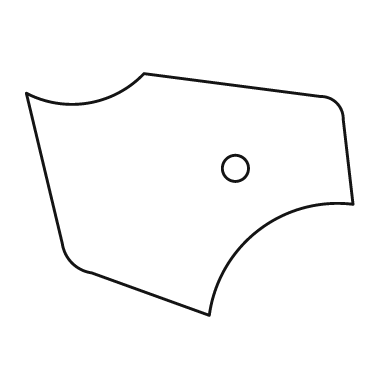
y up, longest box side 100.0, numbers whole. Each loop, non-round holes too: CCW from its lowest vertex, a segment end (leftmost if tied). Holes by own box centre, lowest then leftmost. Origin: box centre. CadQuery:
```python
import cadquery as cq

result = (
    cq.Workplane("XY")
    .moveTo(6.0, -37.0)
    .threePointArc((21.0, -11.0), (50.0, -3.0))
    .lineTo(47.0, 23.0)
    .threePointArc((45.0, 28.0), (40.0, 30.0))
    .lineTo(-14.0, 37.0)
    .threePointArc((-31.0, 28.0), (-50.0, 31.0))
    .lineTo(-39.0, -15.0)
    .threePointArc((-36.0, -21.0), (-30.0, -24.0))
    .close()
    .moveTo(14.0, 8.0)
    .circle(4.0)
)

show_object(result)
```